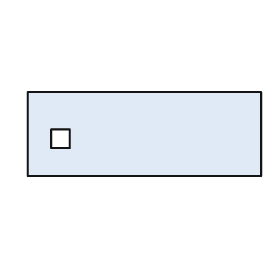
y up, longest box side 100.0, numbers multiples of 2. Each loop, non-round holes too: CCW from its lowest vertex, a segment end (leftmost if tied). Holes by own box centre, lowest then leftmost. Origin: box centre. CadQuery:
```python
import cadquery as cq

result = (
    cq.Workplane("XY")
    .moveTo(-50.0, -18.0)
    .lineTo(50.0, -18.0)
    .lineTo(50.0, 18.0)
    .lineTo(-50.0, 18.0)
    .close()
    .moveTo(-40.0, -6.0)
    .lineTo(-32.0, -6.0)
    .lineTo(-32.0, 2.0)
    .lineTo(-40.0, 2.0)
    .close()
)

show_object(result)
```